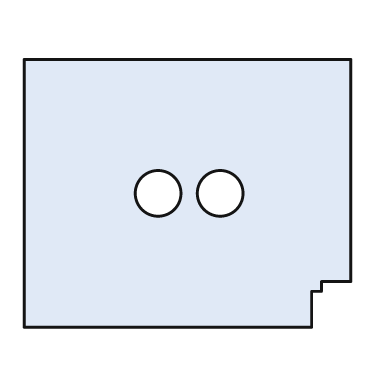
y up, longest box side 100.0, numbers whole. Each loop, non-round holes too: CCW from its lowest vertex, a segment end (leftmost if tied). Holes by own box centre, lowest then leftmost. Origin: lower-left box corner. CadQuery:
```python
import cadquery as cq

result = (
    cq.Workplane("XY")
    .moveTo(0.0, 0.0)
    .lineTo(88.0, 0.0)
    .lineTo(88.0, 11.0)
    .lineTo(91.0, 11.0)
    .lineTo(91.0, 14.0)
    .lineTo(100.0, 14.0)
    .lineTo(100.0, 82.0)
    .lineTo(0.0, 82.0)
    .close()
    .moveTo(41.0, 41.0)
    .circle(7.0)
    .moveTo(60.0, 41.0)
    .circle(7.0)
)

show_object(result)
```